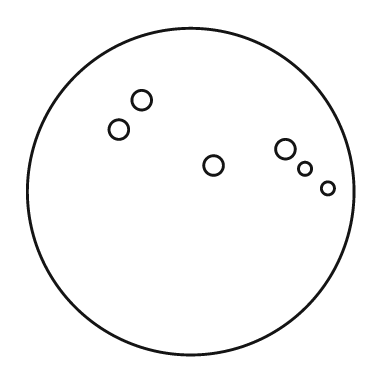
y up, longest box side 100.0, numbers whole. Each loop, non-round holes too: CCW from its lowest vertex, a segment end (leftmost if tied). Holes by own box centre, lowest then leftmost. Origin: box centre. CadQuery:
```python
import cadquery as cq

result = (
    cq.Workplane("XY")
    .moveTo(0.0, 0.0)
    .circle(50.0)
    .moveTo(42.0, 1.0)
    .circle(2.0)
    .moveTo(35.0, 7.0)
    .circle(2.0)
    .moveTo(7.0, 8.0)
    .circle(3.0)
    .moveTo(29.0, 13.0)
    .circle(3.0)
    .moveTo(-22.0, 19.0)
    .circle(3.0)
    .moveTo(-15.0, 28.0)
    .circle(3.0)
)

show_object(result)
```